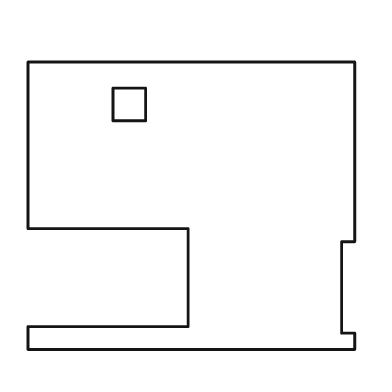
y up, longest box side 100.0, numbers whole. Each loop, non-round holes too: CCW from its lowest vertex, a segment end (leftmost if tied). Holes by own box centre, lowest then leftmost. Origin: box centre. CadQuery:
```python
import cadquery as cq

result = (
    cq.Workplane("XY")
    .moveTo(-50.0, -44.0)
    .lineTo(50.0, -44.0)
    .lineTo(50.0, -39.0)
    .lineTo(46.0, -39.0)
    .lineTo(46.0, -11.0)
    .lineTo(50.0, -11.0)
    .lineTo(50.0, 44.0)
    .lineTo(-50.0, 44.0)
    .lineTo(-50.0, -7.0)
    .lineTo(-1.0, -7.0)
    .lineTo(-1.0, -37.0)
    .lineTo(-50.0, -37.0)
    .close()
    .moveTo(-24.0, 26.0)
    .lineTo(-14.0, 26.0)
    .lineTo(-14.0, 36.0)
    .lineTo(-24.0, 36.0)
    .close()
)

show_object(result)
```